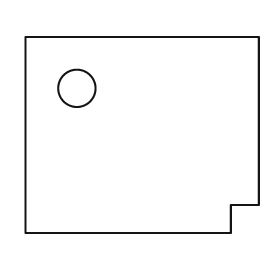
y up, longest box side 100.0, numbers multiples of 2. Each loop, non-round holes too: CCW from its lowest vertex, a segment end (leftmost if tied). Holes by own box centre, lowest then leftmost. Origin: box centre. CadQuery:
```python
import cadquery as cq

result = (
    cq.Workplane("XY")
    .moveTo(-50.0, -42.0)
    .lineTo(38.0, -42.0)
    .lineTo(38.0, -30.0)
    .lineTo(50.0, -30.0)
    .lineTo(50.0, 42.0)
    .lineTo(-50.0, 42.0)
    .close()
    .moveTo(-28.0, 20.0)
    .circle(8.0)
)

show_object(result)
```